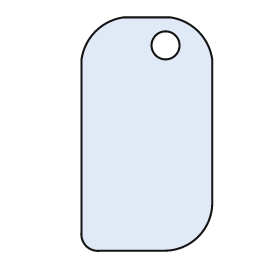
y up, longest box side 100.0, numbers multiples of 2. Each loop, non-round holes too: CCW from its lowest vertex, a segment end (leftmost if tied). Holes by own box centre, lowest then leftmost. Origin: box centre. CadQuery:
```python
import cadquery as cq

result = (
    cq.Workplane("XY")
    .moveTo(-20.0, -50.0)
    .lineTo(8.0, -50.0)
    .threePointArc((22.0, -44.0), (28.0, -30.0))
    .lineTo(28.0, 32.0)
    .threePointArc((22.0, 44.0), (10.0, 50.0))
    .lineTo(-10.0, 50.0)
    .threePointArc((-22.0, 44.0), (-28.0, 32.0))
    .lineTo(-28.0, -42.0)
    .threePointArc((-26.0, -48.0), (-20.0, -50.0))
    .close()
    .moveTo(8.0, 38.0)
    .circle(6.0)
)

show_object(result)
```